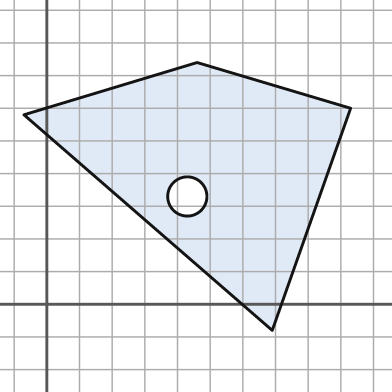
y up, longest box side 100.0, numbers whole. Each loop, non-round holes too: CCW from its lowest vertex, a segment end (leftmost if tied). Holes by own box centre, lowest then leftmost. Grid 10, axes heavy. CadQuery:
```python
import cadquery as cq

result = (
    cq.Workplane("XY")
    .moveTo(69.0, -8.0)
    .lineTo(93.0, 60.0)
    .lineTo(46.0, 74.0)
    .lineTo(-7.0, 58.0)
    .close()
    .moveTo(43.0, 33.0)
    .circle(6.0)
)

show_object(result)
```